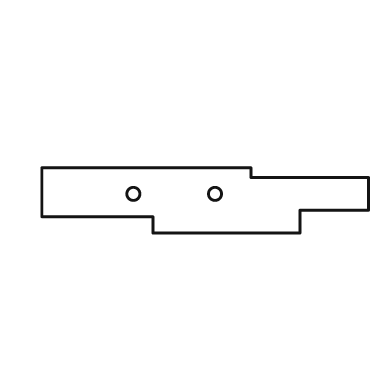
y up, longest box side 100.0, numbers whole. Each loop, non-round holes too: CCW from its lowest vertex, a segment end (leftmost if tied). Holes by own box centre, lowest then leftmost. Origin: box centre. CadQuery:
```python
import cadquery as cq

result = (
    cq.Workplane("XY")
    .moveTo(-16.0, -10.0)
    .lineTo(29.0, -10.0)
    .lineTo(29.0, -3.0)
    .lineTo(50.0, -3.0)
    .lineTo(50.0, 7.0)
    .lineTo(14.0, 7.0)
    .lineTo(14.0, 10.0)
    .lineTo(-50.0, 10.0)
    .lineTo(-50.0, -5.0)
    .lineTo(-16.0, -5.0)
    .close()
    .moveTo(-22.0, 2.0)
    .circle(2.0)
    .moveTo(3.0, 2.0)
    .circle(2.0)
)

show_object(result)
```